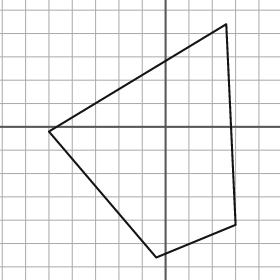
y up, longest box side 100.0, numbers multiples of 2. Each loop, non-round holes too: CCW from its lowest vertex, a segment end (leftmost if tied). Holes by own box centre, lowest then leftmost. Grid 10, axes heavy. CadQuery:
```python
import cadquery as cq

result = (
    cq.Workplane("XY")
    .moveTo(-4.0, -56.0)
    .lineTo(30.0, -42.0)
    .lineTo(26.0, 44.0)
    .lineTo(-50.0, -2.0)
    .close()
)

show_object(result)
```